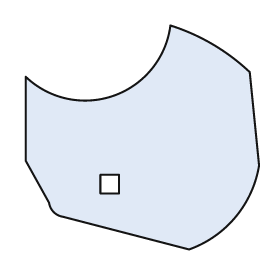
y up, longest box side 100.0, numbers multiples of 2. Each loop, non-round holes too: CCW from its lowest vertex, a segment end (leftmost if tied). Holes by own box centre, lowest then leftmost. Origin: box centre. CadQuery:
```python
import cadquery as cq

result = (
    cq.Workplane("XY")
    .moveTo(20.0, -48.0)
    .threePointArc((40.0, -34.0), (50.0, -12.0))
    .lineTo(46.0, 28.0)
    .threePointArc((30.0, 40.0), (12.0, 48.0))
    .threePointArc((-12.0, 18.0), (-50.0, 26.0))
    .lineTo(-50.0, -10.0)
    .lineTo(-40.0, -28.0)
    .threePointArc((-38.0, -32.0), (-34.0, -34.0))
    .close()
    .moveTo(-18.0, -24.0)
    .lineTo(-10.0, -24.0)
    .lineTo(-10.0, -16.0)
    .lineTo(-18.0, -16.0)
    .close()
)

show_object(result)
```